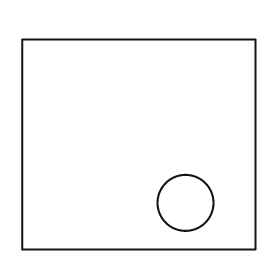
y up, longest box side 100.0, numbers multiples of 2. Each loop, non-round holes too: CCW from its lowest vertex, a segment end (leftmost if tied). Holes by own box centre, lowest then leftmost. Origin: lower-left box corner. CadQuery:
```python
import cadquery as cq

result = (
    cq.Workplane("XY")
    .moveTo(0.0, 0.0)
    .lineTo(100.0, 0.0)
    .lineTo(100.0, 90.0)
    .lineTo(0.0, 90.0)
    .close()
    .moveTo(70.0, 20.0)
    .circle(12.0)
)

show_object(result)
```